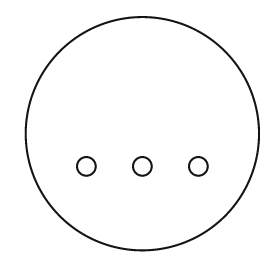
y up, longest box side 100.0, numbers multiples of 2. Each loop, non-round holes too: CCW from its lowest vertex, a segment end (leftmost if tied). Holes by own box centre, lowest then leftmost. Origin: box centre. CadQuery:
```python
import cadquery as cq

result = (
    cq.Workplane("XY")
    .moveTo(0.0, 0.0)
    .circle(50.0)
    .moveTo(-24.0, -14.0)
    .circle(4.0)
    .moveTo(0.0, -14.0)
    .circle(4.0)
    .moveTo(24.0, -14.0)
    .circle(4.0)
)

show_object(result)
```